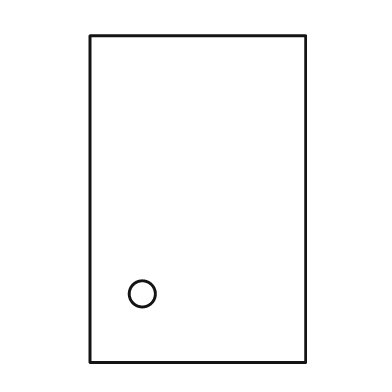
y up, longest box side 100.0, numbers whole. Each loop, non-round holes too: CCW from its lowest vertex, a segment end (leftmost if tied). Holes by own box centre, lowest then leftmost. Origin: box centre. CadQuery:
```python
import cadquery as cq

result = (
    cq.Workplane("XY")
    .moveTo(-33.0, -50.0)
    .lineTo(33.0, -50.0)
    .lineTo(33.0, 50.0)
    .lineTo(-33.0, 50.0)
    .close()
    .moveTo(-17.0, -29.0)
    .circle(4.0)
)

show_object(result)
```